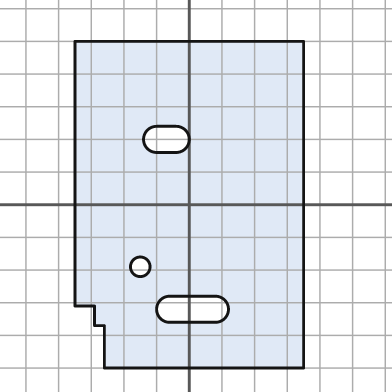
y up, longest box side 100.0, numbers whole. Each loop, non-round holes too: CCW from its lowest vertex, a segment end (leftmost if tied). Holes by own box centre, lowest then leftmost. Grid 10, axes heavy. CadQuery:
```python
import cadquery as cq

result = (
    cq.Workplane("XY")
    .moveTo(-26.0, -50.0)
    .lineTo(35.0, -50.0)
    .lineTo(35.0, 50.0)
    .lineTo(-35.0, 50.0)
    .lineTo(-35.0, -31.0)
    .lineTo(-29.0, -31.0)
    .lineTo(-29.0, -37.0)
    .lineTo(-26.0, -37.0)
    .close()
    .moveTo(-6.0, -36.0)
    .lineTo(8.0, -36.0)
    .threePointArc((12.0, -32.0), (8.0, -28.0))
    .lineTo(-6.0, -28.0)
    .threePointArc((-10.0, -32.0), (-6.0, -36.0))
    .close()
    .moveTo(-15.0, -19.0)
    .circle(3.0)
    .moveTo(-10.0, 16.0)
    .lineTo(-4.0, 16.0)
    .threePointArc((0.0, 20.0), (-4.0, 24.0))
    .lineTo(-10.0, 24.0)
    .threePointArc((-14.0, 20.0), (-10.0, 16.0))
    .close()
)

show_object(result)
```